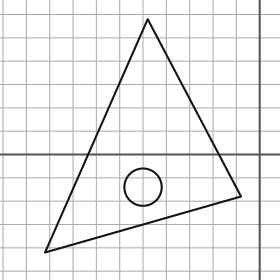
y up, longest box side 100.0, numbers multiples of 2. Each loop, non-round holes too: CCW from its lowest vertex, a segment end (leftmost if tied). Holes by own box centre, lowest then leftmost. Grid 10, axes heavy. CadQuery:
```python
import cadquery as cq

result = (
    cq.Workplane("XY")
    .moveTo(-92.0, -42.0)
    .lineTo(-8.0, -18.0)
    .lineTo(-48.0, 58.0)
    .close()
    .moveTo(-50.0, -14.0)
    .circle(8.0)
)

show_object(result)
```